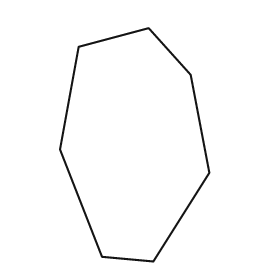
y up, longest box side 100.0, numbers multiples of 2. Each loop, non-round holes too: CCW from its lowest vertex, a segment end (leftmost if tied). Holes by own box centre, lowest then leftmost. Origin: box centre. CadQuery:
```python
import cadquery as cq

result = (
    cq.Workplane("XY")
    .moveTo(8.0, -50.0)
    .lineTo(32.0, -12.0)
    .lineTo(24.0, 30.0)
    .lineTo(6.0, 50.0)
    .lineTo(-24.0, 42.0)
    .lineTo(-32.0, -2.0)
    .lineTo(-14.0, -48.0)
    .close()
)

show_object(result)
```